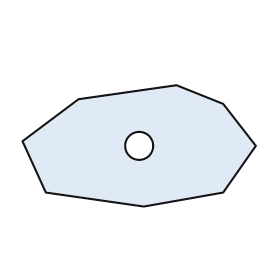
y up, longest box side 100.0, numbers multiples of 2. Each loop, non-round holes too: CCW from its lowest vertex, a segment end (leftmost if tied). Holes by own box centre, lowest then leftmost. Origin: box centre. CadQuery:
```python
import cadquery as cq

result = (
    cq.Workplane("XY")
    .moveTo(2.0, -26.0)
    .lineTo(36.0, -20.0)
    .lineTo(50.0, 0.0)
    .lineTo(36.0, 18.0)
    .lineTo(16.0, 26.0)
    .lineTo(-26.0, 20.0)
    .lineTo(-50.0, 2.0)
    .lineTo(-40.0, -20.0)
    .close()
    .moveTo(0.0, 0.0)
    .circle(6.0)
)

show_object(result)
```